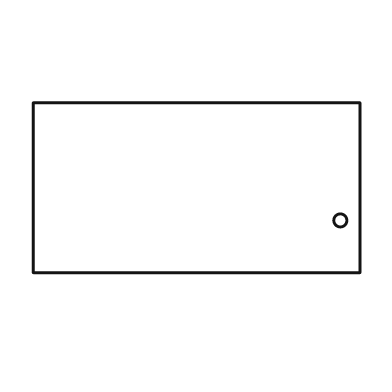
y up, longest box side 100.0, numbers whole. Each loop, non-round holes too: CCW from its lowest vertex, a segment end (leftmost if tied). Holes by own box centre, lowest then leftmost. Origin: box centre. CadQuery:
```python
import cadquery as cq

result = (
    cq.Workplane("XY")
    .moveTo(-50.0, -26.0)
    .lineTo(50.0, -26.0)
    .lineTo(50.0, 26.0)
    .lineTo(-50.0, 26.0)
    .close()
    .moveTo(44.0, -10.0)
    .circle(2.0)
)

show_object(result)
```